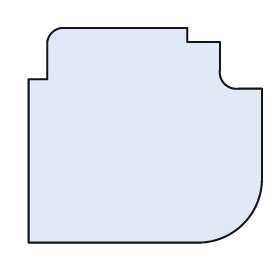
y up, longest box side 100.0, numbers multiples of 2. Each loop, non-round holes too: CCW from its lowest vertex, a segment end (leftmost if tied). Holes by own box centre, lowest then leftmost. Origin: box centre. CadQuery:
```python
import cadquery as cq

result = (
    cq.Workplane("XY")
    .moveTo(-50.0, -46.0)
    .lineTo(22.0, -46.0)
    .threePointArc((42.0, -38.0), (50.0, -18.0))
    .lineTo(50.0, 20.0)
    .lineTo(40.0, 20.0)
    .threePointArc((34.0, 22.0), (32.0, 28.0))
    .lineTo(32.0, 40.0)
    .lineTo(18.0, 40.0)
    .lineTo(18.0, 46.0)
    .lineTo(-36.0, 46.0)
    .threePointArc((-40.0, 44.0), (-42.0, 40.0))
    .lineTo(-42.0, 24.0)
    .lineTo(-50.0, 24.0)
    .close()
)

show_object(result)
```